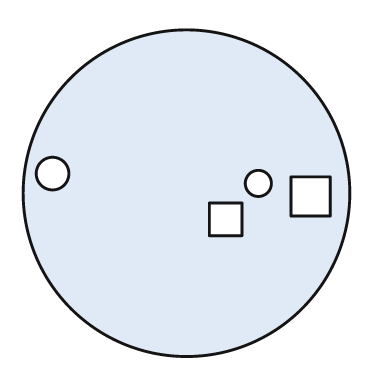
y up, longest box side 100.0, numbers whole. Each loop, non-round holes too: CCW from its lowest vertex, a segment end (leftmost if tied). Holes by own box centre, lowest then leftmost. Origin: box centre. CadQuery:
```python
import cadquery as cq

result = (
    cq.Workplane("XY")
    .moveTo(0.0, 0.0)
    .circle(50.0)
    .moveTo(7.0, -13.0)
    .lineTo(17.0, -13.0)
    .lineTo(17.0, -3.0)
    .lineTo(7.0, -3.0)
    .close()
    .moveTo(32.0, -7.0)
    .lineTo(44.0, -7.0)
    .lineTo(44.0, 5.0)
    .lineTo(32.0, 5.0)
    .close()
    .moveTo(22.0, 3.0)
    .circle(4.0)
    .moveTo(-41.0, 6.0)
    .circle(5.0)
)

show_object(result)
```